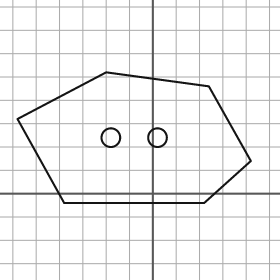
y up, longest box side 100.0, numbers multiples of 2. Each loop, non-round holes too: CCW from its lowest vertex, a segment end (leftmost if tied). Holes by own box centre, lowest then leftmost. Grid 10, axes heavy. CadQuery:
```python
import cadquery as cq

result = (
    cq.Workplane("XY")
    .moveTo(-38.0, -4.0)
    .lineTo(22.0, -4.0)
    .lineTo(42.0, 14.0)
    .lineTo(24.0, 46.0)
    .lineTo(-20.0, 52.0)
    .lineTo(-58.0, 32.0)
    .close()
    .moveTo(-18.0, 24.0)
    .circle(4.0)
    .moveTo(2.0, 24.0)
    .circle(4.0)
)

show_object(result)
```